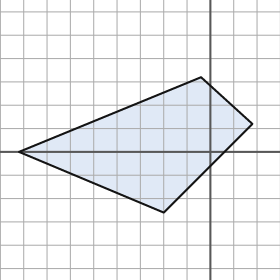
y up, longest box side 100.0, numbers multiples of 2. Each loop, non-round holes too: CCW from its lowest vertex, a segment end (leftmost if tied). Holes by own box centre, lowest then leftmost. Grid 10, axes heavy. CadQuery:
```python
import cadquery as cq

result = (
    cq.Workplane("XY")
    .moveTo(-20.0, -26.0)
    .lineTo(18.0, 12.0)
    .lineTo(-4.0, 32.0)
    .lineTo(-82.0, 0.0)
    .close()
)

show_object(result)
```